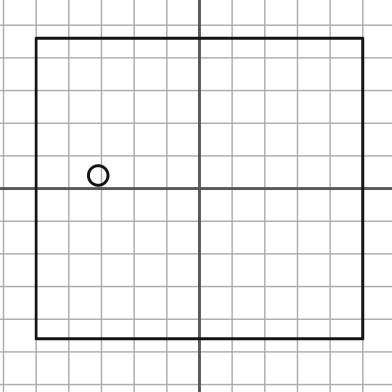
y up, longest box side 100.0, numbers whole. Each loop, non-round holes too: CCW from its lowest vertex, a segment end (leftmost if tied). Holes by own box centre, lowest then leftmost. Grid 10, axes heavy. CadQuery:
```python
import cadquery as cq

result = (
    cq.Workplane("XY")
    .moveTo(-50.0, -46.0)
    .lineTo(50.0, -46.0)
    .lineTo(50.0, 46.0)
    .lineTo(-50.0, 46.0)
    .close()
    .moveTo(-31.0, 4.0)
    .circle(3.0)
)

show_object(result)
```